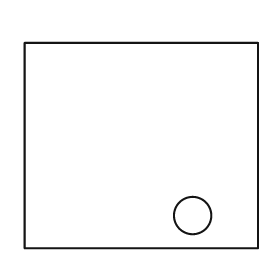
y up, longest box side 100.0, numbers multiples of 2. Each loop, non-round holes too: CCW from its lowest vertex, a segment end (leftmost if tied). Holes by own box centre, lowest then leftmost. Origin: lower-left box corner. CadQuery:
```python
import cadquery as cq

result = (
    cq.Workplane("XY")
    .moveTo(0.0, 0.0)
    .lineTo(100.0, 0.0)
    .lineTo(100.0, 88.0)
    .lineTo(0.0, 88.0)
    .close()
    .moveTo(72.0, 14.0)
    .circle(8.0)
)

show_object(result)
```